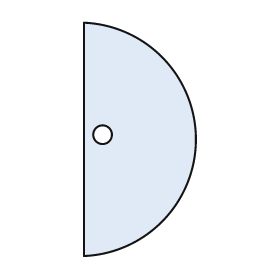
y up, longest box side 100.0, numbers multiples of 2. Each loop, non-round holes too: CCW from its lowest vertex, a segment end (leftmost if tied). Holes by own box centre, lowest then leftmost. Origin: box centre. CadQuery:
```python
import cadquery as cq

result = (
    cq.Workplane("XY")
    .moveTo(-24.0, -50.0)
    .threePointArc((24.0, 0.0), (-24.0, 50.0))
    .close()
    .moveTo(-16.0, 2.0)
    .circle(4.0)
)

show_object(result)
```